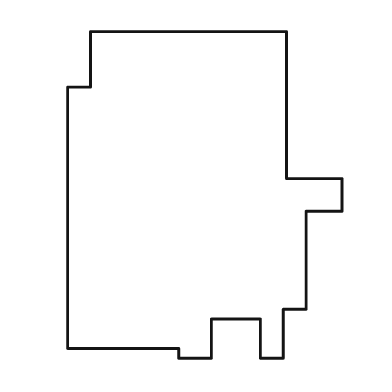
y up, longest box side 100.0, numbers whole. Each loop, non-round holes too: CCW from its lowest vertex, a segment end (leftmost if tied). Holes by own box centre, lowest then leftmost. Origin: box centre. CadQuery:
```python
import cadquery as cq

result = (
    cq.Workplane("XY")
    .moveTo(-8.0, -50.0)
    .lineTo(2.0, -50.0)
    .lineTo(2.0, -38.0)
    .lineTo(17.0, -38.0)
    .lineTo(17.0, -50.0)
    .lineTo(24.0, -50.0)
    .lineTo(24.0, -35.0)
    .lineTo(31.0, -35.0)
    .lineTo(31.0, -5.0)
    .lineTo(42.0, -5.0)
    .lineTo(42.0, 5.0)
    .lineTo(25.0, 5.0)
    .lineTo(25.0, 50.0)
    .lineTo(-35.0, 50.0)
    .lineTo(-35.0, 33.0)
    .lineTo(-42.0, 33.0)
    .lineTo(-42.0, -47.0)
    .lineTo(-8.0, -47.0)
    .close()
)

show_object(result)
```